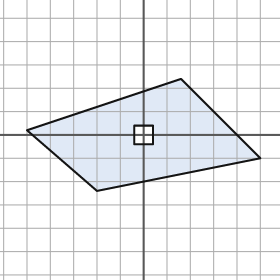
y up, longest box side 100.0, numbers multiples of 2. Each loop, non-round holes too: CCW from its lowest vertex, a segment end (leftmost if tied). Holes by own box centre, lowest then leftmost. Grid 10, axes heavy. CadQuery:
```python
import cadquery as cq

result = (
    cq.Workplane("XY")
    .moveTo(-20.0, -24.0)
    .lineTo(50.0, -10.0)
    .lineTo(16.0, 24.0)
    .lineTo(-50.0, 2.0)
    .close()
    .moveTo(-4.0, -4.0)
    .lineTo(4.0, -4.0)
    .lineTo(4.0, 4.0)
    .lineTo(-4.0, 4.0)
    .close()
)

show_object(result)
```